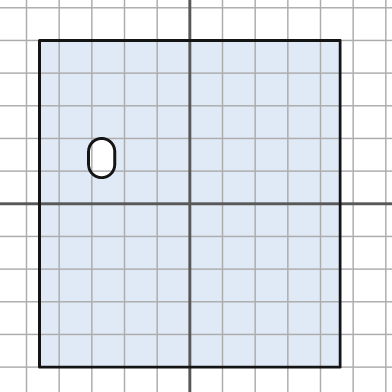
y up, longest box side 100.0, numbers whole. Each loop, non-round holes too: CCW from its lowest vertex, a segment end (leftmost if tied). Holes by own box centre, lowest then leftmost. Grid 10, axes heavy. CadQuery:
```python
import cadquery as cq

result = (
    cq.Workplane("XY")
    .moveTo(-46.0, -50.0)
    .lineTo(46.0, -50.0)
    .lineTo(46.0, 50.0)
    .lineTo(-46.0, 50.0)
    .close()
    .moveTo(-31.0, 12.0)
    .threePointArc((-27.0, 8.0), (-23.0, 12.0))
    .lineTo(-23.0, 16.0)
    .threePointArc((-27.0, 20.0), (-31.0, 16.0))
    .close()
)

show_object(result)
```